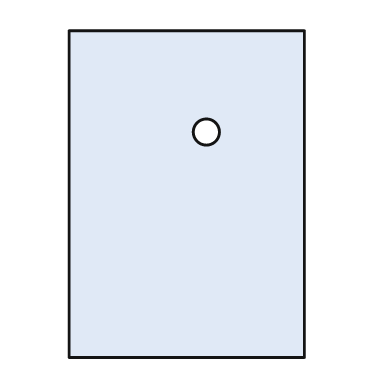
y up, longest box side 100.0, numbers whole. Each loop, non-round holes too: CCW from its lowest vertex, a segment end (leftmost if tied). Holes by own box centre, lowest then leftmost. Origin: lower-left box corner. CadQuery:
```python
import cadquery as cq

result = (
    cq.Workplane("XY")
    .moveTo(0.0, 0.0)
    .lineTo(72.0, 0.0)
    .lineTo(72.0, 100.0)
    .lineTo(0.0, 100.0)
    .close()
    .moveTo(42.0, 69.0)
    .circle(4.0)
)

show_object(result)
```